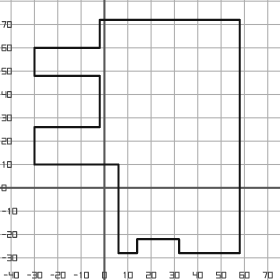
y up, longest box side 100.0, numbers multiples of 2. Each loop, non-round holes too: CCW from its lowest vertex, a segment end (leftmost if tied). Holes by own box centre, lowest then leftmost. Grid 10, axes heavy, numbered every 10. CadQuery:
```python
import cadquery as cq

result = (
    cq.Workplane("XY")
    .moveTo(6.0, -28.0)
    .lineTo(14.0, -28.0)
    .lineTo(14.0, -22.0)
    .lineTo(32.0, -22.0)
    .lineTo(32.0, -28.0)
    .lineTo(58.0, -28.0)
    .lineTo(58.0, 72.0)
    .lineTo(-2.0, 72.0)
    .lineTo(-2.0, 60.0)
    .lineTo(-30.0, 60.0)
    .lineTo(-30.0, 48.0)
    .lineTo(-2.0, 48.0)
    .lineTo(-2.0, 26.0)
    .lineTo(-30.0, 26.0)
    .lineTo(-30.0, 10.0)
    .lineTo(6.0, 10.0)
    .close()
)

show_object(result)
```